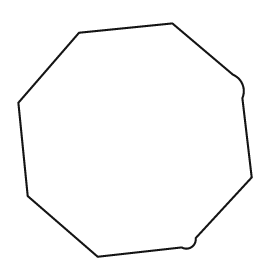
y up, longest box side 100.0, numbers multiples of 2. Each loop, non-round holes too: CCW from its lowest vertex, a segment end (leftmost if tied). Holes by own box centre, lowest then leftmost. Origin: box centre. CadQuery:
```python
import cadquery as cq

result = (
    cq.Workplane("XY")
    .moveTo(-16.0, -50.0)
    .lineTo(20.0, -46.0)
    .threePointArc((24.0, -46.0), (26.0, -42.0))
    .lineTo(50.0, -16.0)
    .lineTo(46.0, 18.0)
    .threePointArc((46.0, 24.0), (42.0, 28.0))
    .lineTo(16.0, 50.0)
    .lineTo(-24.0, 46.0)
    .lineTo(-50.0, 16.0)
    .lineTo(-46.0, -24.0)
    .close()
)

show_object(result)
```